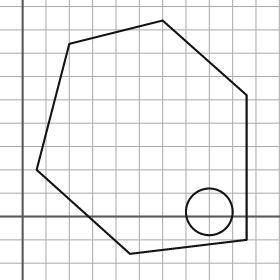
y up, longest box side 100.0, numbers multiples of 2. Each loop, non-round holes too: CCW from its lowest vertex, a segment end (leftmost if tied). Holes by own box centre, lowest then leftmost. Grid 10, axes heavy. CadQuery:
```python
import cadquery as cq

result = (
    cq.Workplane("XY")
    .moveTo(46.0, -16.0)
    .lineTo(96.0, -10.0)
    .lineTo(96.0, 52.0)
    .lineTo(60.0, 84.0)
    .lineTo(20.0, 74.0)
    .lineTo(6.0, 20.0)
    .close()
    .moveTo(80.0, 2.0)
    .circle(10.0)
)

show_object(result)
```